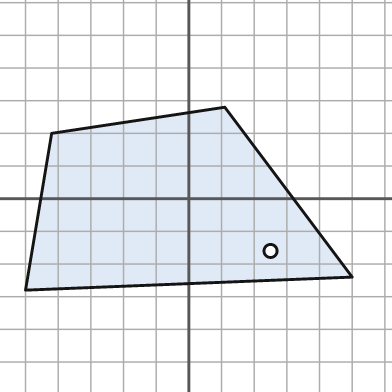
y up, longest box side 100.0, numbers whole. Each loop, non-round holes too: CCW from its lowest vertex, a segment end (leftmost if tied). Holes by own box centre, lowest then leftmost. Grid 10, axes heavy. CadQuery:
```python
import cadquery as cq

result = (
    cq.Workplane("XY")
    .moveTo(-50.0, -28.0)
    .lineTo(50.0, -24.0)
    .lineTo(11.0, 28.0)
    .lineTo(-42.0, 20.0)
    .close()
    .moveTo(25.0, -16.0)
    .circle(2.0)
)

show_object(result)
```